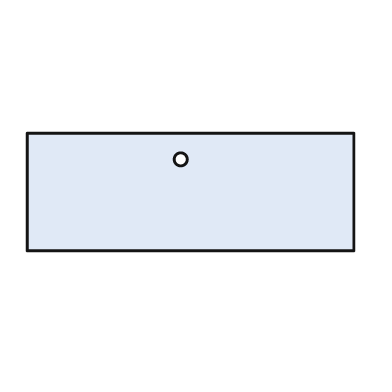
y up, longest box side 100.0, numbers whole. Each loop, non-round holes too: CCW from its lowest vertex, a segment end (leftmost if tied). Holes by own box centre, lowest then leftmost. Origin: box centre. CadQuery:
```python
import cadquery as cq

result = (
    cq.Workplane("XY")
    .moveTo(-50.0, -18.0)
    .lineTo(50.0, -18.0)
    .lineTo(50.0, 18.0)
    .lineTo(-50.0, 18.0)
    .close()
    .moveTo(-3.0, 10.0)
    .circle(2.0)
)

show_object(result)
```